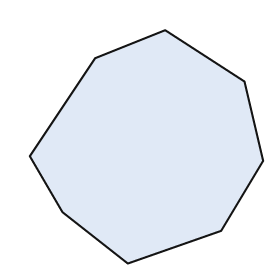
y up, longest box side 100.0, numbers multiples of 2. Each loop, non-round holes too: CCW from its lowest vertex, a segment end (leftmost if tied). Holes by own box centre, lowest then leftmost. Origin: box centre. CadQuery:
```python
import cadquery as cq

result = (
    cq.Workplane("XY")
    .moveTo(-8.0, -50.0)
    .lineTo(32.0, -36.0)
    .lineTo(50.0, -6.0)
    .lineTo(42.0, 28.0)
    .lineTo(8.0, 50.0)
    .lineTo(-22.0, 38.0)
    .lineTo(-50.0, -4.0)
    .lineTo(-36.0, -28.0)
    .close()
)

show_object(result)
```